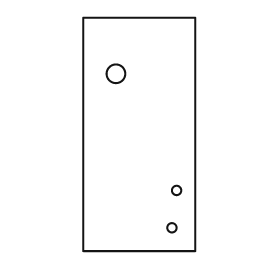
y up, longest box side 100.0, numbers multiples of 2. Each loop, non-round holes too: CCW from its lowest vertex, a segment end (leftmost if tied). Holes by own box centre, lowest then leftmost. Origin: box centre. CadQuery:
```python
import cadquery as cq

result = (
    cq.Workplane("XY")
    .moveTo(-24.0, -50.0)
    .lineTo(24.0, -50.0)
    .lineTo(24.0, 50.0)
    .lineTo(-24.0, 50.0)
    .close()
    .moveTo(14.0, -40.0)
    .circle(2.0)
    .moveTo(16.0, -24.0)
    .circle(2.0)
    .moveTo(-10.0, 26.0)
    .circle(4.0)
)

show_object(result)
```